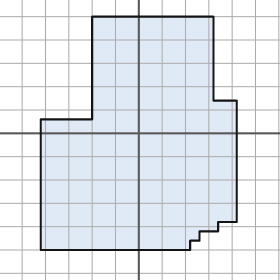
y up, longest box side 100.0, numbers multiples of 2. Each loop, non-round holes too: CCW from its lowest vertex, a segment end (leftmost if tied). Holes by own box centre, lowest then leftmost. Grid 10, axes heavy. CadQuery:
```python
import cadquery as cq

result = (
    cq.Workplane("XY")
    .moveTo(-42.0, -50.0)
    .lineTo(22.0, -50.0)
    .lineTo(22.0, -46.0)
    .lineTo(26.0, -46.0)
    .lineTo(26.0, -42.0)
    .lineTo(34.0, -42.0)
    .lineTo(34.0, -38.0)
    .lineTo(42.0, -38.0)
    .lineTo(42.0, 14.0)
    .lineTo(32.0, 14.0)
    .lineTo(32.0, 50.0)
    .lineTo(-20.0, 50.0)
    .lineTo(-20.0, 6.0)
    .lineTo(-42.0, 6.0)
    .close()
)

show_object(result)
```